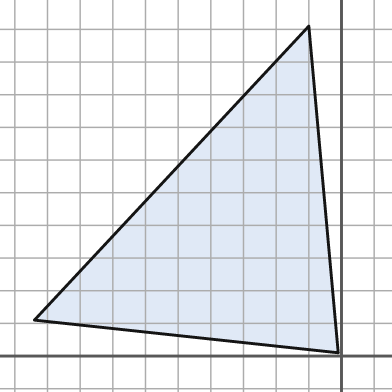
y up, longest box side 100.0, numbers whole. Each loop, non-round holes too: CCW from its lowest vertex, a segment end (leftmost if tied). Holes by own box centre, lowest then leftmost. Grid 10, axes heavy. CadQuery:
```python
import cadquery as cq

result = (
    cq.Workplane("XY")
    .moveTo(-1.0, 1.0)
    .lineTo(-10.0, 101.0)
    .lineTo(-94.0, 11.0)
    .close()
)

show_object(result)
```